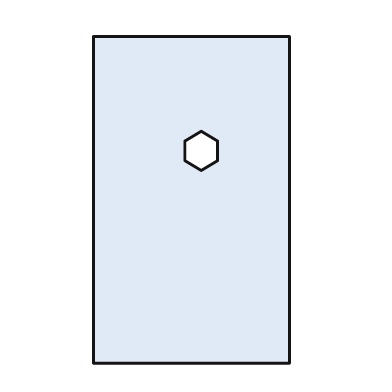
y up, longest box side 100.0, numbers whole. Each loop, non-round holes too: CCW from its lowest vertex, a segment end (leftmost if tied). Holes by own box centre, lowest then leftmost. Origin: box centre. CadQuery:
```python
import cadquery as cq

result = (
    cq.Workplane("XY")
    .moveTo(-30.0, -50.0)
    .lineTo(30.0, -50.0)
    .lineTo(30.0, 50.0)
    .lineTo(-30.0, 50.0)
    .close()
    .moveTo(3.0, 9.0)
    .lineTo(8.0, 12.0)
    .lineTo(8.0, 18.0)
    .lineTo(3.0, 21.0)
    .lineTo(-2.0, 18.0)
    .lineTo(-2.0, 12.0)
    .close()
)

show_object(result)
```